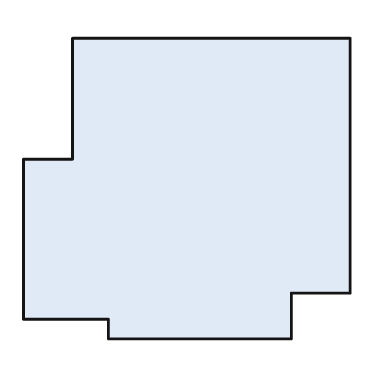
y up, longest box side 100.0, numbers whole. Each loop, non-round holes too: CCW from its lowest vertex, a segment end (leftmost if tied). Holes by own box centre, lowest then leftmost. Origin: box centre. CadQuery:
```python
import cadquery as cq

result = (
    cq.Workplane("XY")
    .moveTo(-24.0, -46.0)
    .lineTo(32.0, -46.0)
    .lineTo(32.0, -32.0)
    .lineTo(50.0, -32.0)
    .lineTo(50.0, 46.0)
    .lineTo(-35.0, 46.0)
    .lineTo(-35.0, 9.0)
    .lineTo(-50.0, 9.0)
    .lineTo(-50.0, -40.0)
    .lineTo(-24.0, -40.0)
    .close()
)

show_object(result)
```